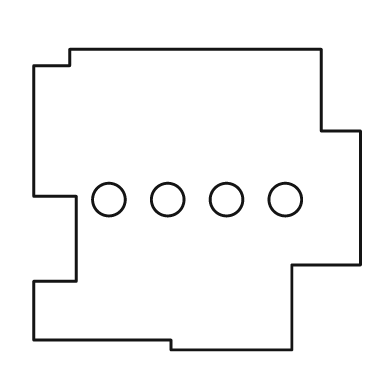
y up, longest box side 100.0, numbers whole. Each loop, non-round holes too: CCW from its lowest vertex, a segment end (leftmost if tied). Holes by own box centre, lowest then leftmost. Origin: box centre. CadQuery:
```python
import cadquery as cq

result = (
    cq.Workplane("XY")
    .moveTo(-8.0, -46.0)
    .lineTo(29.0, -46.0)
    .lineTo(29.0, -20.0)
    .lineTo(50.0, -20.0)
    .lineTo(50.0, 21.0)
    .lineTo(38.0, 21.0)
    .lineTo(38.0, 46.0)
    .lineTo(-39.0, 46.0)
    .lineTo(-39.0, 41.0)
    .lineTo(-50.0, 41.0)
    .lineTo(-50.0, 1.0)
    .lineTo(-37.0, 1.0)
    .lineTo(-37.0, -25.0)
    .lineTo(-50.0, -25.0)
    .lineTo(-50.0, -43.0)
    .lineTo(-8.0, -43.0)
    .close()
    .moveTo(-27.0, 0.0)
    .circle(5.0)
    .moveTo(-9.0, 0.0)
    .circle(5.0)
    .moveTo(9.0, 0.0)
    .circle(5.0)
    .moveTo(27.0, 0.0)
    .circle(5.0)
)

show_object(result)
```